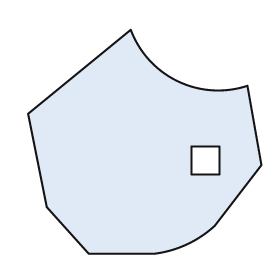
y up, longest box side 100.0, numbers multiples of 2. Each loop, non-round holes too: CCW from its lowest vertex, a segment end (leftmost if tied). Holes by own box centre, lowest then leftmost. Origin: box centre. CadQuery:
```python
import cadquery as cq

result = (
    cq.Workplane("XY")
    .moveTo(-24.0, -48.0)
    .lineTo(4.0, -48.0)
    .threePointArc((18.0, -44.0), (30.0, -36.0))
    .lineTo(50.0, -10.0)
    .lineTo(44.0, 24.0)
    .threePointArc((14.0, 26.0), (-6.0, 48.0))
    .lineTo(-50.0, 12.0)
    .lineTo(-42.0, -28.0)
    .close()
    .moveTo(20.0, -14.0)
    .lineTo(32.0, -14.0)
    .lineTo(32.0, -2.0)
    .lineTo(20.0, -2.0)
    .close()
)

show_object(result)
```